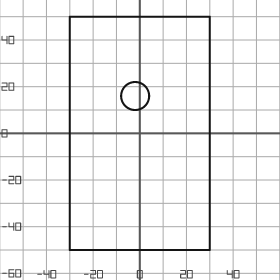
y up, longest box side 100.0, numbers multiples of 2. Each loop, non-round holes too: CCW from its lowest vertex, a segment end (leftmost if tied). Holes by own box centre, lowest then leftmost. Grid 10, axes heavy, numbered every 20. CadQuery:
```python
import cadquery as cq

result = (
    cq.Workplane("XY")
    .moveTo(-30.0, -50.0)
    .lineTo(30.0, -50.0)
    .lineTo(30.0, 50.0)
    .lineTo(-30.0, 50.0)
    .close()
    .moveTo(-2.0, 16.0)
    .circle(6.0)
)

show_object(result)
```